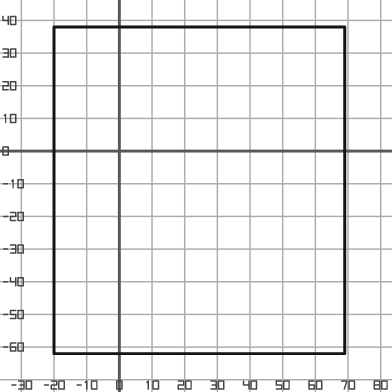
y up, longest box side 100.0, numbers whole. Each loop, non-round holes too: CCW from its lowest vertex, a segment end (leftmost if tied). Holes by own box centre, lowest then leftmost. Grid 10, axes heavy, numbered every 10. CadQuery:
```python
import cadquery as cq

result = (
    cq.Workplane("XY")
    .moveTo(-20.0, -62.0)
    .lineTo(69.0, -62.0)
    .lineTo(69.0, 38.0)
    .lineTo(-20.0, 38.0)
    .close()
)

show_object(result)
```